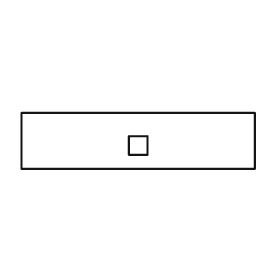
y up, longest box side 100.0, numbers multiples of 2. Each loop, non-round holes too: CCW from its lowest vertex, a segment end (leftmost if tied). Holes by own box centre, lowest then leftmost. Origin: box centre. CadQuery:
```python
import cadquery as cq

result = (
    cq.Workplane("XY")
    .moveTo(-50.0, -12.0)
    .lineTo(50.0, -12.0)
    .lineTo(50.0, 12.0)
    .lineTo(-50.0, 12.0)
    .close()
    .moveTo(-4.0, -6.0)
    .lineTo(4.0, -6.0)
    .lineTo(4.0, 2.0)
    .lineTo(-4.0, 2.0)
    .close()
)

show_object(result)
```